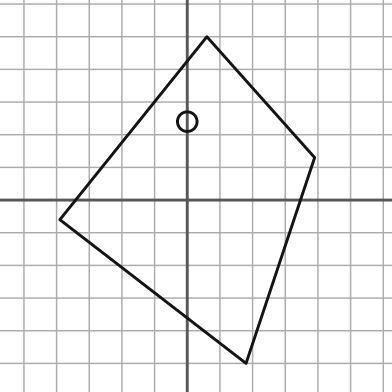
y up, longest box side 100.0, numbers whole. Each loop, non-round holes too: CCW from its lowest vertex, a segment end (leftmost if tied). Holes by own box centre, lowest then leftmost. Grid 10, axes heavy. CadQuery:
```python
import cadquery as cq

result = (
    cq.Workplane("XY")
    .moveTo(18.0, -50.0)
    .lineTo(39.0, 13.0)
    .lineTo(6.0, 50.0)
    .lineTo(-39.0, -6.0)
    .close()
    .moveTo(0.0, 24.0)
    .circle(3.0)
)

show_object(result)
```